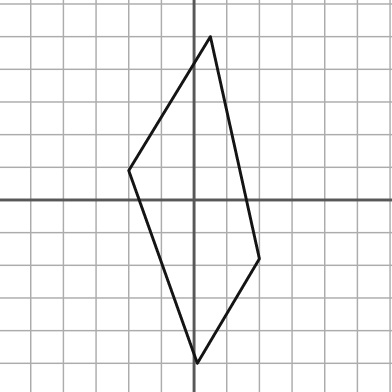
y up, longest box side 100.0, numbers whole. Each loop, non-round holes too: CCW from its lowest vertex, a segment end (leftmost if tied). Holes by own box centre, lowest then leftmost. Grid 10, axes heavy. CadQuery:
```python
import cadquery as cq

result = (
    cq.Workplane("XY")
    .moveTo(1.0, -50.0)
    .lineTo(20.0, -18.0)
    .lineTo(5.0, 50.0)
    .lineTo(-20.0, 9.0)
    .close()
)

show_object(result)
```